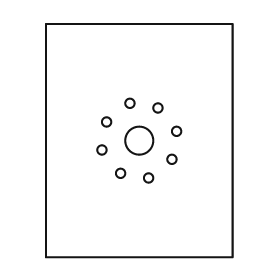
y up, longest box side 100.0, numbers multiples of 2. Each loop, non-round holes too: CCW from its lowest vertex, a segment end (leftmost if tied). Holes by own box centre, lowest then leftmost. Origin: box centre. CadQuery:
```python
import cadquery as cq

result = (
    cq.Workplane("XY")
    .moveTo(-40.0, -50.0)
    .lineTo(40.0, -50.0)
    .lineTo(40.0, 50.0)
    .lineTo(-40.0, 50.0)
    .close()
    .moveTo(4.0, -16.0)
    .circle(2.0)
    .moveTo(-8.0, -14.0)
    .circle(2.0)
    .moveTo(14.0, -8.0)
    .circle(2.0)
    .moveTo(-16.0, -4.0)
    .circle(2.0)
    .moveTo(0.0, 0.0)
    .circle(6.0)
    .moveTo(16.0, 4.0)
    .circle(2.0)
    .moveTo(-14.0, 8.0)
    .circle(2.0)
    .moveTo(8.0, 14.0)
    .circle(2.0)
    .moveTo(-4.0, 16.0)
    .circle(2.0)
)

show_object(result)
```